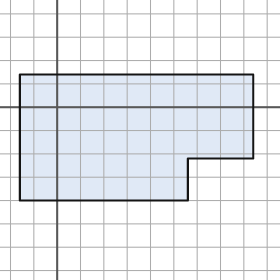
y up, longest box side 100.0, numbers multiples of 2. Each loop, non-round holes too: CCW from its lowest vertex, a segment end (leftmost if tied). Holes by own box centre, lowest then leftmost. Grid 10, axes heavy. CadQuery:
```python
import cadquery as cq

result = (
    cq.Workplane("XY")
    .moveTo(-16.0, -40.0)
    .lineTo(56.0, -40.0)
    .lineTo(56.0, -22.0)
    .lineTo(84.0, -22.0)
    .lineTo(84.0, 14.0)
    .lineTo(-16.0, 14.0)
    .close()
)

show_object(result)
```